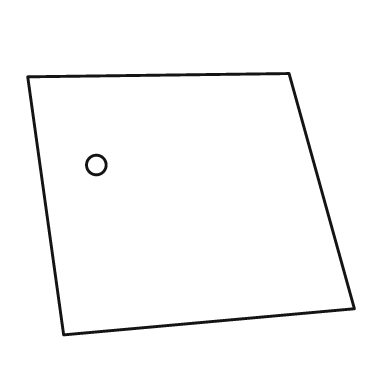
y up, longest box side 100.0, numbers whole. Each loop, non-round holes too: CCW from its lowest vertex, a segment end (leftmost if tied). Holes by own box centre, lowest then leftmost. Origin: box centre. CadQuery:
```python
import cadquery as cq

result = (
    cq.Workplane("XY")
    .moveTo(-39.0, -40.0)
    .lineTo(50.0, -32.0)
    .lineTo(30.0, 40.0)
    .lineTo(-50.0, 39.0)
    .close()
    .moveTo(-29.0, 12.0)
    .circle(3.0)
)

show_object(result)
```